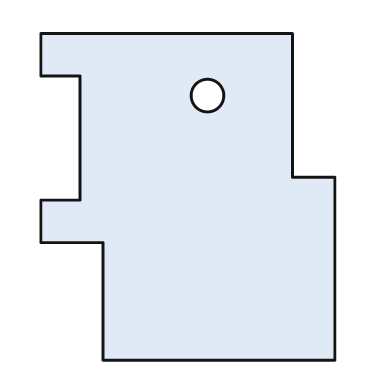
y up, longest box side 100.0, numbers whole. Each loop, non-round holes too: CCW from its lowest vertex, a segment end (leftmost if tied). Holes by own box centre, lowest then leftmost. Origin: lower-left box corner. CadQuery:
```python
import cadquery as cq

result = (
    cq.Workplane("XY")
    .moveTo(19.0, 0.0)
    .lineTo(90.0, 0.0)
    .lineTo(90.0, 56.0)
    .lineTo(77.0, 56.0)
    .lineTo(77.0, 100.0)
    .lineTo(0.0, 100.0)
    .lineTo(0.0, 87.0)
    .lineTo(12.0, 87.0)
    .lineTo(12.0, 49.0)
    .lineTo(0.0, 49.0)
    .lineTo(0.0, 36.0)
    .lineTo(19.0, 36.0)
    .close()
    .moveTo(51.0, 81.0)
    .circle(5.0)
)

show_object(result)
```